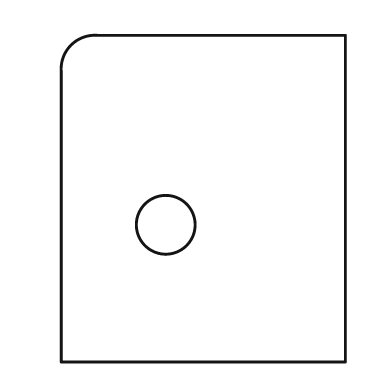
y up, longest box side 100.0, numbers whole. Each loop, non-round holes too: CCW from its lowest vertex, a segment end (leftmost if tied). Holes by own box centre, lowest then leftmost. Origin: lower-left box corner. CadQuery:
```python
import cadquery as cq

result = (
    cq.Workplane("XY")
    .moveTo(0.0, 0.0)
    .lineTo(87.0, 0.0)
    .lineTo(87.0, 100.0)
    .lineTo(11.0, 100.0)
    .threePointArc((3.0, 97.0), (0.0, 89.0))
    .close()
    .moveTo(32.0, 42.0)
    .circle(9.0)
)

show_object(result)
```